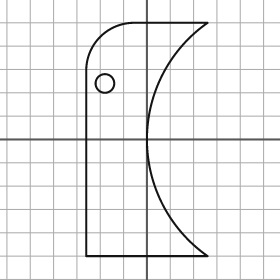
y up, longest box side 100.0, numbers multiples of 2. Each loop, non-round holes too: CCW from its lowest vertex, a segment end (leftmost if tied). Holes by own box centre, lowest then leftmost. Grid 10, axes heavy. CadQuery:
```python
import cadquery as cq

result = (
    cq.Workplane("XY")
    .moveTo(-26.0, -50.0)
    .lineTo(26.0, -50.0)
    .threePointArc((0.0, 0.0), (26.0, 50.0))
    .lineTo(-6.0, 50.0)
    .threePointArc((-20.0, 44.0), (-26.0, 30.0))
    .close()
    .moveTo(-18.0, 24.0)
    .circle(4.0)
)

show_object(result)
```